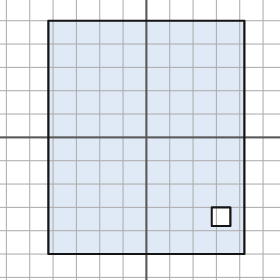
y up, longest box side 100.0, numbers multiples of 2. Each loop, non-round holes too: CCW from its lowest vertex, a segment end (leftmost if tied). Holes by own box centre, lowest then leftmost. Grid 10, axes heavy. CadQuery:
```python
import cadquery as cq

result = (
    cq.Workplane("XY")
    .moveTo(-42.0, -50.0)
    .lineTo(42.0, -50.0)
    .lineTo(42.0, 50.0)
    .lineTo(-42.0, 50.0)
    .close()
    .moveTo(28.0, -38.0)
    .lineTo(36.0, -38.0)
    .lineTo(36.0, -30.0)
    .lineTo(28.0, -30.0)
    .close()
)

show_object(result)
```